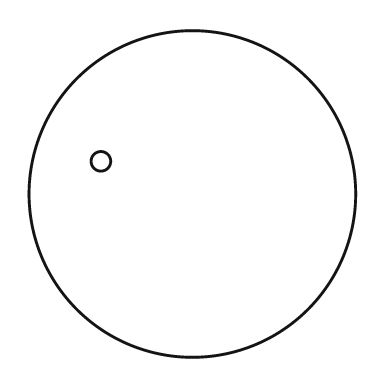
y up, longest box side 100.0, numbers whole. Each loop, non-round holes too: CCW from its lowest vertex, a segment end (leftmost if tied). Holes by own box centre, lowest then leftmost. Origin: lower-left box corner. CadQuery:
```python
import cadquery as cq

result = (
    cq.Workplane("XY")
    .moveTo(50.0, 50.0)
    .circle(50.0)
    .moveTo(22.0, 60.0)
    .circle(3.0)
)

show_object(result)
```